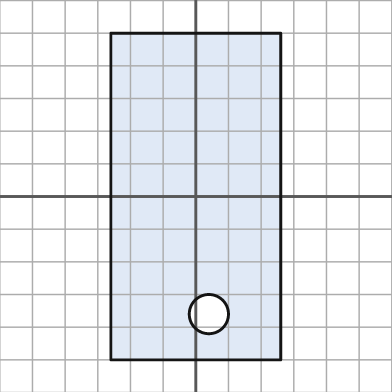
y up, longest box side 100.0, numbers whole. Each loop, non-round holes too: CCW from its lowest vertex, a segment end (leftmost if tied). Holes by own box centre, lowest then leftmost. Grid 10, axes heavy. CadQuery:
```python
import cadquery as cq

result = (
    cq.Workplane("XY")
    .moveTo(-26.0, -50.0)
    .lineTo(26.0, -50.0)
    .lineTo(26.0, 50.0)
    .lineTo(-26.0, 50.0)
    .close()
    .moveTo(4.0, -36.0)
    .circle(6.0)
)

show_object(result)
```